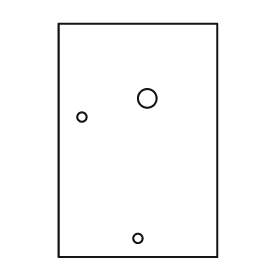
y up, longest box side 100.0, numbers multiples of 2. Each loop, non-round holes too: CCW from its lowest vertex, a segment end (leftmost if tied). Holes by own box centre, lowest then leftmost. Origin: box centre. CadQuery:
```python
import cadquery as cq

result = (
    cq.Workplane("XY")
    .moveTo(-34.0, -50.0)
    .lineTo(34.0, -50.0)
    .lineTo(34.0, 50.0)
    .lineTo(-34.0, 50.0)
    .close()
    .moveTo(0.0, -42.0)
    .circle(2.0)
    .moveTo(-24.0, 10.0)
    .circle(2.0)
    .moveTo(4.0, 18.0)
    .circle(4.0)
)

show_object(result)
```